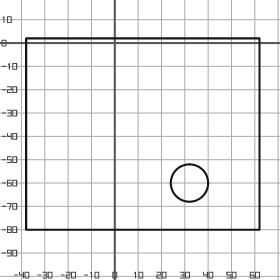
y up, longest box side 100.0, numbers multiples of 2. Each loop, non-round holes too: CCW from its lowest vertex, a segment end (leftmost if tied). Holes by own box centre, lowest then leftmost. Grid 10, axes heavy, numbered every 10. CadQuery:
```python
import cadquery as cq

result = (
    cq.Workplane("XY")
    .moveTo(-38.0, -80.0)
    .lineTo(62.0, -80.0)
    .lineTo(62.0, 2.0)
    .lineTo(-38.0, 2.0)
    .close()
    .moveTo(32.0, -60.0)
    .circle(8.0)
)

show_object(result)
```